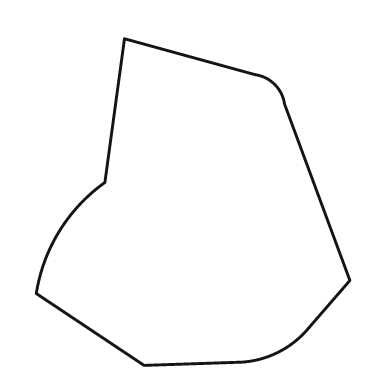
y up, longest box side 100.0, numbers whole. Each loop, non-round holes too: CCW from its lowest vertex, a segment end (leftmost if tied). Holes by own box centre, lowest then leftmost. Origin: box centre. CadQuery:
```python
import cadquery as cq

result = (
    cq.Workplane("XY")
    .moveTo(-15.0, -50.0)
    .lineTo(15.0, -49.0)
    .threePointArc((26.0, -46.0), (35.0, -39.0))
    .lineTo(48.0, -24.0)
    .lineTo(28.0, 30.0)
    .threePointArc((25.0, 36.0), (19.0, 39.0))
    .lineTo(-21.0, 50.0)
    .lineTo(-27.0, 6.0)
    .threePointArc((-41.0, -9.0), (-48.0, -28.0))
    .close()
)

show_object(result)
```